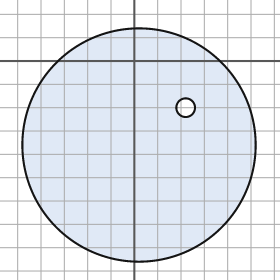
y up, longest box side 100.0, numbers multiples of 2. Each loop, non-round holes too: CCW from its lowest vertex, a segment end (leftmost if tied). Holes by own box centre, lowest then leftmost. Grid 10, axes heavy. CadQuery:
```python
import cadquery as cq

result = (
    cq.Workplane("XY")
    .moveTo(2.0, -36.0)
    .circle(50.0)
    .moveTo(22.0, -20.0)
    .circle(4.0)
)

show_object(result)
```